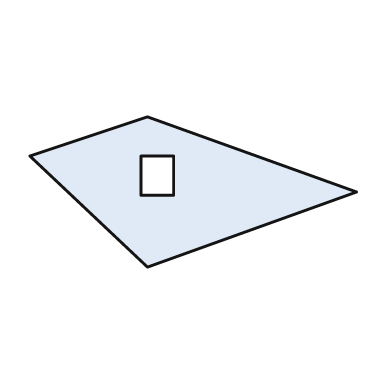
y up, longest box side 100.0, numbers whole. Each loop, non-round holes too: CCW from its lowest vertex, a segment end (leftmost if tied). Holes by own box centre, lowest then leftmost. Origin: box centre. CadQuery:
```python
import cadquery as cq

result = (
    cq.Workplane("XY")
    .moveTo(-14.0, -23.0)
    .lineTo(50.0, 0.0)
    .lineTo(-14.0, 23.0)
    .lineTo(-50.0, 11.0)
    .close()
    .moveTo(-16.0, -1.0)
    .lineTo(-6.0, -1.0)
    .lineTo(-6.0, 11.0)
    .lineTo(-16.0, 11.0)
    .close()
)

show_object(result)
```